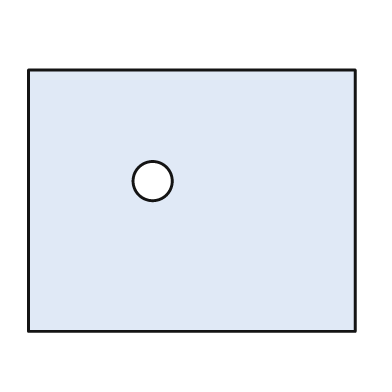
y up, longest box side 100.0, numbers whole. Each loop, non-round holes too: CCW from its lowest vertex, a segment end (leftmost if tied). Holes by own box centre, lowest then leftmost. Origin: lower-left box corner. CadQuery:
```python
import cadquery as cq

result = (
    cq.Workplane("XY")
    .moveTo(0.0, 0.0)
    .lineTo(100.0, 0.0)
    .lineTo(100.0, 80.0)
    .lineTo(0.0, 80.0)
    .close()
    .moveTo(38.0, 46.0)
    .circle(6.0)
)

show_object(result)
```